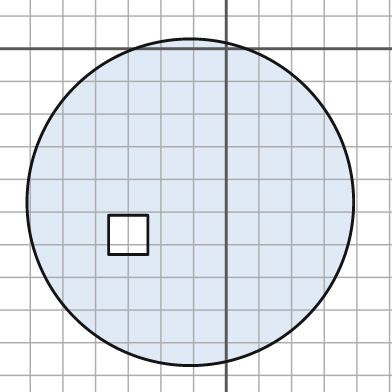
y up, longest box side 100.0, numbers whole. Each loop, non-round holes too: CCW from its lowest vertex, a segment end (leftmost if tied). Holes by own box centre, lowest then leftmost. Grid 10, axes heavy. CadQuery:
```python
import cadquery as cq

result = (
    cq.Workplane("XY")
    .moveTo(-11.0, -47.0)
    .circle(50.0)
    .moveTo(-36.0, -63.0)
    .lineTo(-24.0, -63.0)
    .lineTo(-24.0, -51.0)
    .lineTo(-36.0, -51.0)
    .close()
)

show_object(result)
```